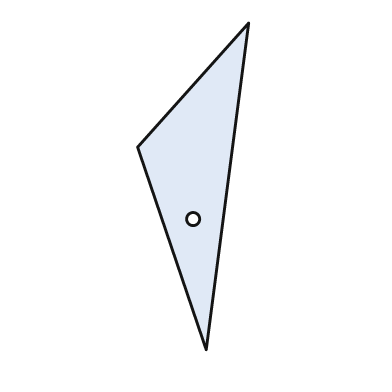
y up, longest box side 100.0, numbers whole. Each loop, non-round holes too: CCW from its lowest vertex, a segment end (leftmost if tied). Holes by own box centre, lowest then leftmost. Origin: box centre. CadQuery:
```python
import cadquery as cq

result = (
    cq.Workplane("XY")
    .moveTo(4.0, -50.0)
    .lineTo(17.0, 50.0)
    .lineTo(-17.0, 12.0)
    .close()
    .moveTo(0.0, -10.0)
    .circle(2.0)
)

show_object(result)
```